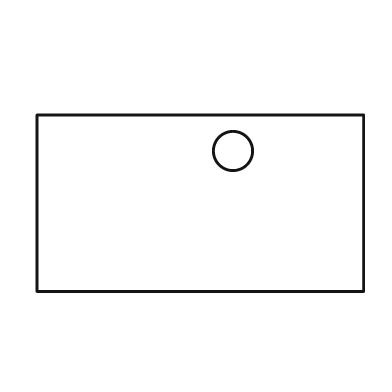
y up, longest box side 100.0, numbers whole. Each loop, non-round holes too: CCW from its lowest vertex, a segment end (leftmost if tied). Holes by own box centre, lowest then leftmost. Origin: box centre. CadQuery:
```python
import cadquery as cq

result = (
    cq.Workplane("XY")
    .moveTo(-50.0, -27.0)
    .lineTo(50.0, -27.0)
    .lineTo(50.0, 27.0)
    .lineTo(-50.0, 27.0)
    .close()
    .moveTo(10.0, 16.0)
    .circle(6.0)
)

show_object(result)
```